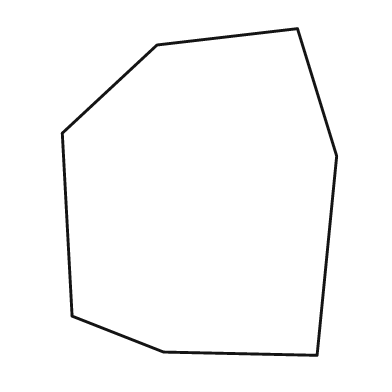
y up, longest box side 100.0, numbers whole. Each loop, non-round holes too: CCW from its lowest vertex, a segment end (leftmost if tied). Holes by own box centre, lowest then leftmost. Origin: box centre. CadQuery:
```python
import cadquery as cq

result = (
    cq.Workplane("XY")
    .moveTo(36.0, -50.0)
    .lineTo(42.0, 11.0)
    .lineTo(30.0, 50.0)
    .lineTo(-13.0, 45.0)
    .lineTo(-42.0, 18.0)
    .lineTo(-39.0, -38.0)
    .lineTo(-11.0, -49.0)
    .close()
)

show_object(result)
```